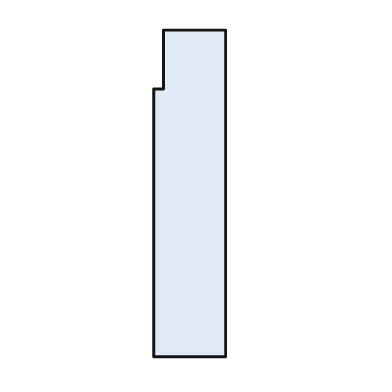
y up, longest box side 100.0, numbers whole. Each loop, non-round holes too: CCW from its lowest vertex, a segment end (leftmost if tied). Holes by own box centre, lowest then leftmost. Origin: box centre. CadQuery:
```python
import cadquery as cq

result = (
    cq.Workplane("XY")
    .moveTo(-11.0, -50.0)
    .lineTo(11.0, -50.0)
    .lineTo(11.0, 50.0)
    .lineTo(-8.0, 50.0)
    .lineTo(-8.0, 32.0)
    .lineTo(-11.0, 32.0)
    .close()
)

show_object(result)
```